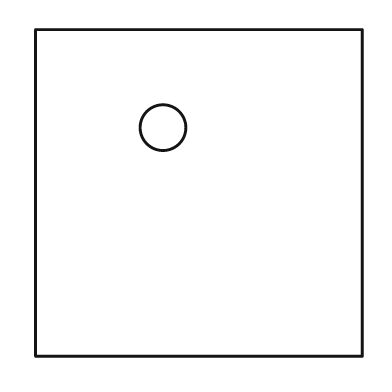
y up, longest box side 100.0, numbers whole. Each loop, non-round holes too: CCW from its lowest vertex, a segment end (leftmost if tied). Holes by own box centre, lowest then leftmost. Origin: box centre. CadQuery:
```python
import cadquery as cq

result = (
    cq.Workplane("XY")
    .moveTo(-50.0, -50.0)
    .lineTo(50.0, -50.0)
    .lineTo(50.0, 50.0)
    .lineTo(-50.0, 50.0)
    .close()
    .moveTo(-11.0, 20.0)
    .circle(7.0)
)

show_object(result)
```